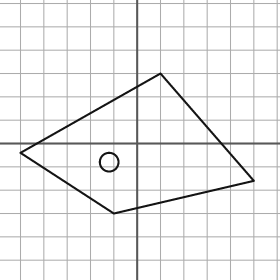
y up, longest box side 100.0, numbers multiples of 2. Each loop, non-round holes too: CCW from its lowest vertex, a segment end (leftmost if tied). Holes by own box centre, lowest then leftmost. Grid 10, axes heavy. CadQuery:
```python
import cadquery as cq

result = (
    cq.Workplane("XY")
    .moveTo(-10.0, -30.0)
    .lineTo(50.0, -16.0)
    .lineTo(10.0, 30.0)
    .lineTo(-50.0, -4.0)
    .close()
    .moveTo(-12.0, -8.0)
    .circle(4.0)
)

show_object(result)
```